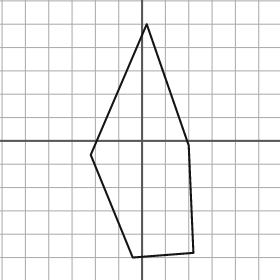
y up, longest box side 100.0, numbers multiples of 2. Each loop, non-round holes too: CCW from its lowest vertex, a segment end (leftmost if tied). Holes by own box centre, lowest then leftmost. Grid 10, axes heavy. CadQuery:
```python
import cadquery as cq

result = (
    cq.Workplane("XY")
    .moveTo(-4.0, -50.0)
    .lineTo(22.0, -48.0)
    .lineTo(20.0, -2.0)
    .lineTo(2.0, 50.0)
    .lineTo(-22.0, -6.0)
    .close()
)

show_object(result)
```